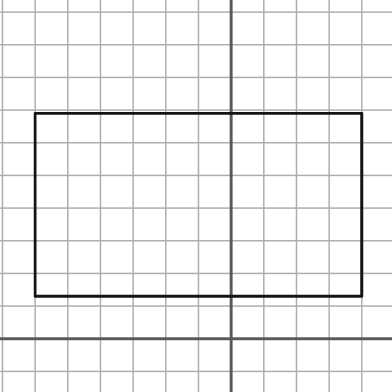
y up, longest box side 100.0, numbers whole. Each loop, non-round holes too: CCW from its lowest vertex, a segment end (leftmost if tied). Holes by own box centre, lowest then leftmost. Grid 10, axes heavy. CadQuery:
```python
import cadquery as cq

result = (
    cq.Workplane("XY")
    .moveTo(-60.0, 13.0)
    .lineTo(40.0, 13.0)
    .lineTo(40.0, 69.0)
    .lineTo(-60.0, 69.0)
    .close()
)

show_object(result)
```